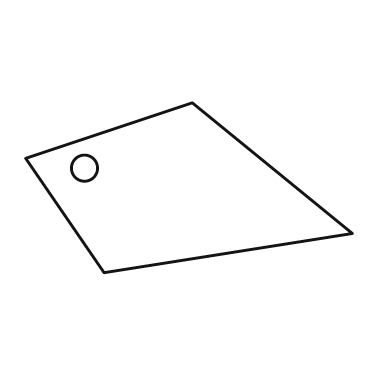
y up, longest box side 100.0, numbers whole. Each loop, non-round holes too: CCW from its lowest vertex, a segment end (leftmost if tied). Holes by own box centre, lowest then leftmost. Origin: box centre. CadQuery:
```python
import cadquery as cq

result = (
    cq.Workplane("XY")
    .moveTo(-26.0, -26.0)
    .lineTo(50.0, -14.0)
    .lineTo(1.0, 26.0)
    .lineTo(-50.0, 9.0)
    .close()
    .moveTo(-32.0, 6.0)
    .circle(4.0)
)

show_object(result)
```